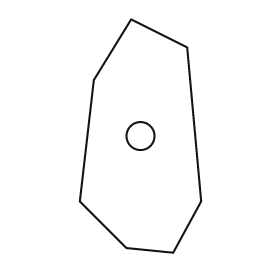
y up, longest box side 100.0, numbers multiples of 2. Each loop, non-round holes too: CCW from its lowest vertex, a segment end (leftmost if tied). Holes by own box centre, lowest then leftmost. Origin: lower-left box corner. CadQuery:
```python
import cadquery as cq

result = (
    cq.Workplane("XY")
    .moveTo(40.0, 0.0)
    .lineTo(52.0, 22.0)
    .lineTo(46.0, 88.0)
    .lineTo(22.0, 100.0)
    .lineTo(6.0, 74.0)
    .lineTo(0.0, 22.0)
    .lineTo(20.0, 2.0)
    .close()
    .moveTo(26.0, 50.0)
    .circle(6.0)
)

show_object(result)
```